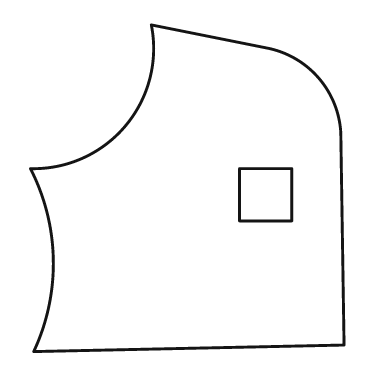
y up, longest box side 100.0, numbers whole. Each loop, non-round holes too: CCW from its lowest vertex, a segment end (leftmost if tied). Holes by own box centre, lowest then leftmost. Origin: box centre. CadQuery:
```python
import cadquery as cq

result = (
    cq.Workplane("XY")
    .moveTo(-47.0, -50.0)
    .lineTo(48.0, -48.0)
    .lineTo(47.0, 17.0)
    .threePointArc((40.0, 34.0), (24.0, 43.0))
    .lineTo(-11.0, 50.0)
    .threePointArc((-19.0, 19.0), (-48.0, 6.0))
    .threePointArc((-41.0, -22.0), (-47.0, -50.0))
    .close()
    .moveTo(16.0, -10.0)
    .lineTo(32.0, -10.0)
    .lineTo(32.0, 6.0)
    .lineTo(16.0, 6.0)
    .close()
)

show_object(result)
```